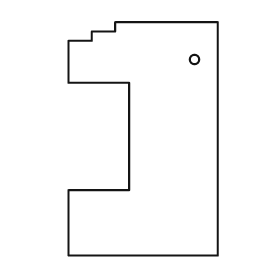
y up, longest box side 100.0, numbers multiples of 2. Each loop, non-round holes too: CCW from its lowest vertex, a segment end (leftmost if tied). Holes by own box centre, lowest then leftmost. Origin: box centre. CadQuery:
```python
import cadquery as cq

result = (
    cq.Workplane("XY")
    .moveTo(-32.0, -50.0)
    .lineTo(32.0, -50.0)
    .lineTo(32.0, 50.0)
    .lineTo(-12.0, 50.0)
    .lineTo(-12.0, 46.0)
    .lineTo(-22.0, 46.0)
    .lineTo(-22.0, 42.0)
    .lineTo(-32.0, 42.0)
    .lineTo(-32.0, 24.0)
    .lineTo(-6.0, 24.0)
    .lineTo(-6.0, -22.0)
    .lineTo(-32.0, -22.0)
    .close()
    .moveTo(22.0, 34.0)
    .circle(2.0)
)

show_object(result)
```